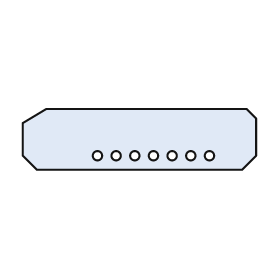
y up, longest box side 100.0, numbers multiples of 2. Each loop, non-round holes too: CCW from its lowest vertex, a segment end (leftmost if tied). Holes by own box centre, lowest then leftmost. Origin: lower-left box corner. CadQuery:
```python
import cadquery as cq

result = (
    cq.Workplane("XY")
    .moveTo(6.0, 0.0)
    .lineTo(94.0, 0.0)
    .lineTo(100.0, 6.0)
    .lineTo(100.0, 22.0)
    .lineTo(96.0, 26.0)
    .lineTo(10.0, 26.0)
    .lineTo(0.0, 20.0)
    .lineTo(0.0, 6.0)
    .close()
    .moveTo(32.0, 6.0)
    .circle(2.0)
    .moveTo(40.0, 6.0)
    .circle(2.0)
    .moveTo(48.0, 6.0)
    .circle(2.0)
    .moveTo(56.0, 6.0)
    .circle(2.0)
    .moveTo(64.0, 6.0)
    .circle(2.0)
    .moveTo(72.0, 6.0)
    .circle(2.0)
    .moveTo(80.0, 6.0)
    .circle(2.0)
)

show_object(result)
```